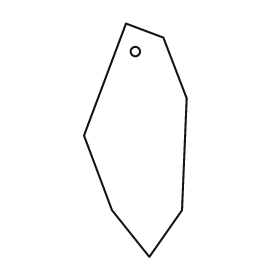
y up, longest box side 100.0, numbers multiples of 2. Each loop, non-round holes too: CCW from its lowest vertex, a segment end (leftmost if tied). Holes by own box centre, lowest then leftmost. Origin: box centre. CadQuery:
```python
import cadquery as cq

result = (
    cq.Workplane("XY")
    .moveTo(6.0, -50.0)
    .lineTo(20.0, -30.0)
    .lineTo(22.0, 18.0)
    .lineTo(12.0, 44.0)
    .lineTo(-4.0, 50.0)
    .lineTo(-22.0, 2.0)
    .lineTo(-10.0, -30.0)
    .close()
    .moveTo(0.0, 38.0)
    .circle(2.0)
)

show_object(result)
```